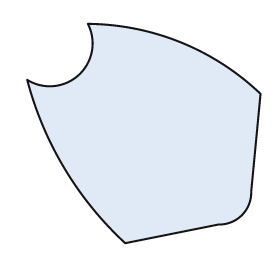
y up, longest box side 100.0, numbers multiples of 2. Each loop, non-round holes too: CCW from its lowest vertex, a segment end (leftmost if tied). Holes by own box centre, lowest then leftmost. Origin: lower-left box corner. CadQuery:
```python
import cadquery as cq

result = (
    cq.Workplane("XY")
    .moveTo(42.0, 0.0)
    .lineTo(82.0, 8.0)
    .threePointArc((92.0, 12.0), (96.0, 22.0))
    .lineTo(100.0, 64.0)
    .threePointArc((66.0, 86.0), (26.0, 94.0))
    .threePointArc((22.0, 72.0), (0.0, 70.0))
    .threePointArc((16.0, 32.0), (42.0, 0.0))
    .close()
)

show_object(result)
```